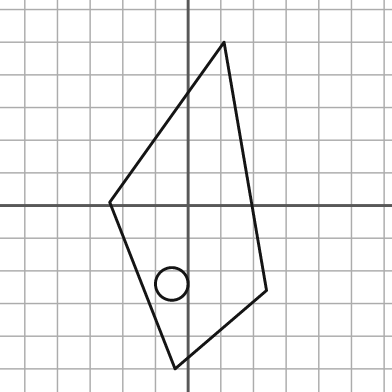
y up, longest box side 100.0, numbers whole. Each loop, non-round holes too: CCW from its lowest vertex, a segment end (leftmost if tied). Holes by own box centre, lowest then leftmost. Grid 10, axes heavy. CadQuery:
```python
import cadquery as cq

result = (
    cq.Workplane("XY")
    .moveTo(-4.0, -50.0)
    .lineTo(24.0, -26.0)
    .lineTo(11.0, 50.0)
    .lineTo(-24.0, 1.0)
    .close()
    .moveTo(-5.0, -24.0)
    .circle(5.0)
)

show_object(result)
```